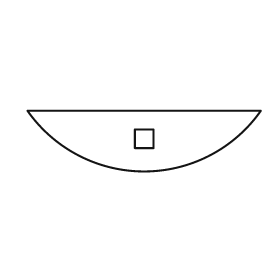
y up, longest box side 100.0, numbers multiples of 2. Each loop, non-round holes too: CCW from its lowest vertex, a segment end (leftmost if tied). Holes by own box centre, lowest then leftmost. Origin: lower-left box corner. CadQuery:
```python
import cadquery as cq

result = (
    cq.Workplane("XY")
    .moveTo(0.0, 26.0)
    .threePointArc((50.0, 0.0), (100.0, 26.0))
    .close()
    .moveTo(46.0, 10.0)
    .lineTo(54.0, 10.0)
    .lineTo(54.0, 18.0)
    .lineTo(46.0, 18.0)
    .close()
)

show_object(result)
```